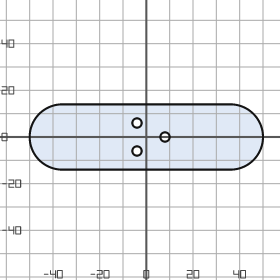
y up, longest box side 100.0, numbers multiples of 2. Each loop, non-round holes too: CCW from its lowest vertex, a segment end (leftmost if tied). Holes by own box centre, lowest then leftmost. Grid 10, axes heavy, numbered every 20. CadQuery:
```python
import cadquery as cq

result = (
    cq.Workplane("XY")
    .moveTo(-36.0, -14.0)
    .lineTo(36.0, -14.0)
    .threePointArc((50.0, 0.0), (36.0, 14.0))
    .lineTo(-36.0, 14.0)
    .threePointArc((-50.0, 0.0), (-36.0, -14.0))
    .close()
    .moveTo(-4.0, -6.0)
    .circle(2.0)
    .moveTo(8.0, 0.0)
    .circle(2.0)
    .moveTo(-4.0, 6.0)
    .circle(2.0)
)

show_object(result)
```